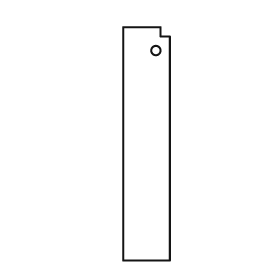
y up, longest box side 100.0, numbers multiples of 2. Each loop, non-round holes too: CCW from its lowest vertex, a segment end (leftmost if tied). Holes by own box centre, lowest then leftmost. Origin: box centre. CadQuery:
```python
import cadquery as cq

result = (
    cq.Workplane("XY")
    .moveTo(-10.0, -50.0)
    .lineTo(10.0, -50.0)
    .lineTo(10.0, 46.0)
    .lineTo(6.0, 46.0)
    .lineTo(6.0, 50.0)
    .lineTo(-10.0, 50.0)
    .close()
    .moveTo(4.0, 40.0)
    .circle(2.0)
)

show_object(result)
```